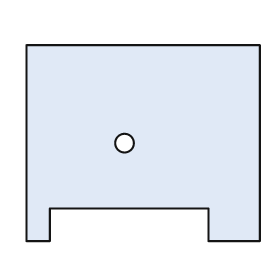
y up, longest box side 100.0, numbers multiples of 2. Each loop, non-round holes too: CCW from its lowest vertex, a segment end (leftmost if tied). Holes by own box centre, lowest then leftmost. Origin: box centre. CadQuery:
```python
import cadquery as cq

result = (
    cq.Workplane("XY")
    .moveTo(-50.0, -42.0)
    .lineTo(-40.0, -42.0)
    .lineTo(-40.0, -28.0)
    .lineTo(28.0, -28.0)
    .lineTo(28.0, -42.0)
    .lineTo(50.0, -42.0)
    .lineTo(50.0, 42.0)
    .lineTo(-50.0, 42.0)
    .close()
    .moveTo(-8.0, 0.0)
    .circle(4.0)
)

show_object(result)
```